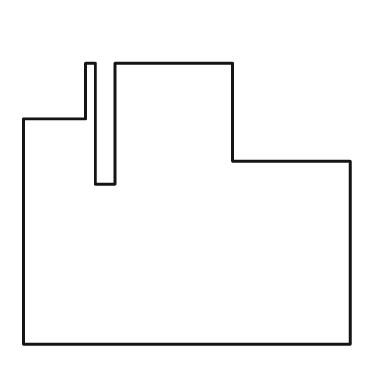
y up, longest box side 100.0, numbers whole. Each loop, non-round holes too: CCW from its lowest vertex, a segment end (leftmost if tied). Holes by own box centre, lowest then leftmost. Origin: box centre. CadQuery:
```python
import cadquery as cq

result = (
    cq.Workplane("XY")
    .moveTo(-50.0, -43.0)
    .lineTo(50.0, -43.0)
    .lineTo(50.0, 13.0)
    .lineTo(14.0, 13.0)
    .lineTo(14.0, 43.0)
    .lineTo(-22.0, 43.0)
    .lineTo(-22.0, 6.0)
    .lineTo(-28.0, 6.0)
    .lineTo(-28.0, 43.0)
    .lineTo(-31.0, 43.0)
    .lineTo(-31.0, 26.0)
    .lineTo(-50.0, 26.0)
    .close()
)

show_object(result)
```